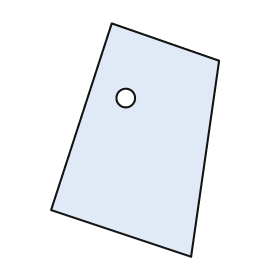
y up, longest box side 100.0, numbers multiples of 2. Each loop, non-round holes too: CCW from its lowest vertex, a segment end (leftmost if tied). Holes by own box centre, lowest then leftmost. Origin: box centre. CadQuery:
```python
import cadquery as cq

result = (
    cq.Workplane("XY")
    .moveTo(24.0, -50.0)
    .lineTo(36.0, 34.0)
    .lineTo(-10.0, 50.0)
    .lineTo(-36.0, -30.0)
    .close()
    .moveTo(-4.0, 18.0)
    .circle(4.0)
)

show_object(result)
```